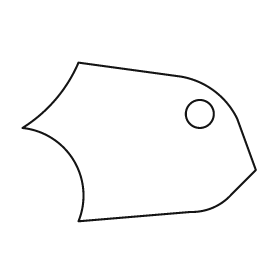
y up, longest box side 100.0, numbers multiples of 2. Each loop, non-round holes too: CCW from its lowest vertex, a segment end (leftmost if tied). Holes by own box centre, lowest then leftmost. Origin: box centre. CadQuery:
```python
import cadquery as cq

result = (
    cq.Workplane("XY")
    .moveTo(-26.0, -34.0)
    .lineTo(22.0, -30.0)
    .threePointArc((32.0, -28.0), (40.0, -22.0))
    .lineTo(50.0, -12.0)
    .lineTo(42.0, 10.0)
    .threePointArc((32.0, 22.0), (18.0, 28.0))
    .lineTo(-26.0, 34.0)
    .threePointArc((-36.0, 18.0), (-50.0, 6.0))
    .threePointArc((-28.0, -8.0), (-26.0, -34.0))
    .close()
    .moveTo(26.0, 12.0)
    .circle(6.0)
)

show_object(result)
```